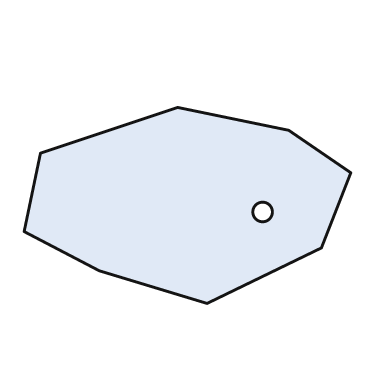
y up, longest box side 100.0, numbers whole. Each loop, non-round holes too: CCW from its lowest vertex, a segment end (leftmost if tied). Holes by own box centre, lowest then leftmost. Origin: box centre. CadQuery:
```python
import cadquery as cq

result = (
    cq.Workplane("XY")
    .moveTo(6.0, -30.0)
    .lineTo(41.0, -13.0)
    .lineTo(50.0, 10.0)
    .lineTo(31.0, 23.0)
    .lineTo(-3.0, 30.0)
    .lineTo(-45.0, 16.0)
    .lineTo(-50.0, -8.0)
    .lineTo(-27.0, -20.0)
    .close()
    .moveTo(23.0, -2.0)
    .circle(3.0)
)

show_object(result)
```